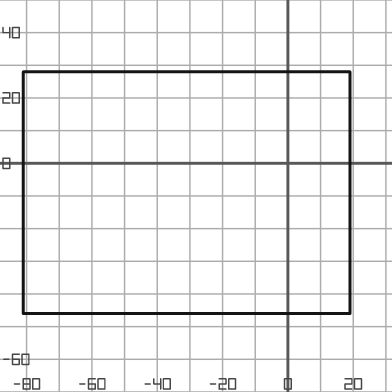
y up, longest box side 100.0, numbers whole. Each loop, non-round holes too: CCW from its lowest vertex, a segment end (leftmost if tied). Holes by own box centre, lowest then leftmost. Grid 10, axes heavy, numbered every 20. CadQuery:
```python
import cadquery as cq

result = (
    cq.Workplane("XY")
    .moveTo(-81.0, -46.0)
    .lineTo(19.0, -46.0)
    .lineTo(19.0, 28.0)
    .lineTo(-81.0, 28.0)
    .close()
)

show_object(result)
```